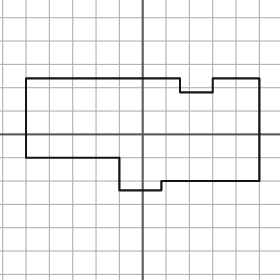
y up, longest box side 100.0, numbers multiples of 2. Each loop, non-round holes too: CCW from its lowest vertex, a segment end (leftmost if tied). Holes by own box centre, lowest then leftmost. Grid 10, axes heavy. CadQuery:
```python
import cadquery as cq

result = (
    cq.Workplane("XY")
    .moveTo(-10.0, -24.0)
    .lineTo(8.0, -24.0)
    .lineTo(8.0, -20.0)
    .lineTo(50.0, -20.0)
    .lineTo(50.0, 24.0)
    .lineTo(30.0, 24.0)
    .lineTo(30.0, 18.0)
    .lineTo(16.0, 18.0)
    .lineTo(16.0, 24.0)
    .lineTo(-50.0, 24.0)
    .lineTo(-50.0, -10.0)
    .lineTo(-10.0, -10.0)
    .close()
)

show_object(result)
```